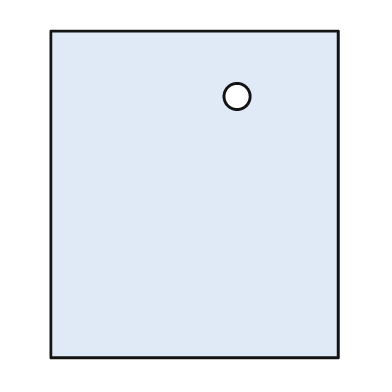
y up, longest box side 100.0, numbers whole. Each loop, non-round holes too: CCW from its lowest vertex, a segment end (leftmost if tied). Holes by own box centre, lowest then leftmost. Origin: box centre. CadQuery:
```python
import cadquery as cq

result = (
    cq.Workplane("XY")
    .moveTo(-44.0, -50.0)
    .lineTo(44.0, -50.0)
    .lineTo(44.0, 50.0)
    .lineTo(-44.0, 50.0)
    .close()
    .moveTo(13.0, 30.0)
    .circle(4.0)
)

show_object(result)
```